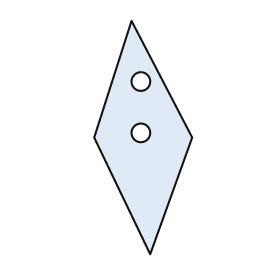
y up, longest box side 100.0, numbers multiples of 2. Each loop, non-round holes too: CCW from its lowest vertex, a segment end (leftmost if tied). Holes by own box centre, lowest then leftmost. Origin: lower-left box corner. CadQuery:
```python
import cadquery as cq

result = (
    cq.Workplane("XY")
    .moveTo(24.0, 0.0)
    .lineTo(42.0, 50.0)
    .lineTo(16.0, 100.0)
    .lineTo(0.0, 50.0)
    .close()
    .moveTo(20.0, 52.0)
    .circle(4.0)
    .moveTo(20.0, 74.0)
    .circle(4.0)
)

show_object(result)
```